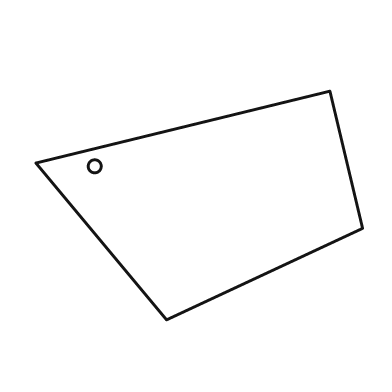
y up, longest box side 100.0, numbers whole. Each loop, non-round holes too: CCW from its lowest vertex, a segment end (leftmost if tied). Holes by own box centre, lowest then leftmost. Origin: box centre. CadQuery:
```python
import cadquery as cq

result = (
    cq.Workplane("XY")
    .moveTo(-10.0, -35.0)
    .lineTo(50.0, -7.0)
    .lineTo(40.0, 35.0)
    .lineTo(-50.0, 13.0)
    .close()
    .moveTo(-32.0, 12.0)
    .circle(2.0)
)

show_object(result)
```